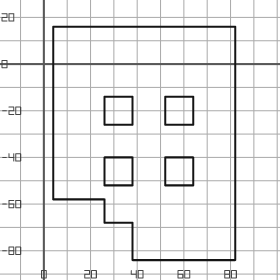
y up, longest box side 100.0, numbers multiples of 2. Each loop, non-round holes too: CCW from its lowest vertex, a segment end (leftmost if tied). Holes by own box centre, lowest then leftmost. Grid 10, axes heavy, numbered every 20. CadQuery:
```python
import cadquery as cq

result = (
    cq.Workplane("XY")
    .moveTo(38.0, -84.0)
    .lineTo(82.0, -84.0)
    .lineTo(82.0, 16.0)
    .lineTo(4.0, 16.0)
    .lineTo(4.0, -58.0)
    .lineTo(26.0, -58.0)
    .lineTo(26.0, -68.0)
    .lineTo(38.0, -68.0)
    .close()
    .moveTo(26.0, -52.0)
    .lineTo(38.0, -52.0)
    .lineTo(38.0, -40.0)
    .lineTo(26.0, -40.0)
    .close()
    .moveTo(52.0, -52.0)
    .lineTo(64.0, -52.0)
    .lineTo(64.0, -40.0)
    .lineTo(52.0, -40.0)
    .close()
    .moveTo(26.0, -26.0)
    .lineTo(38.0, -26.0)
    .lineTo(38.0, -14.0)
    .lineTo(26.0, -14.0)
    .close()
    .moveTo(52.0, -26.0)
    .lineTo(64.0, -26.0)
    .lineTo(64.0, -14.0)
    .lineTo(52.0, -14.0)
    .close()
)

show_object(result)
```